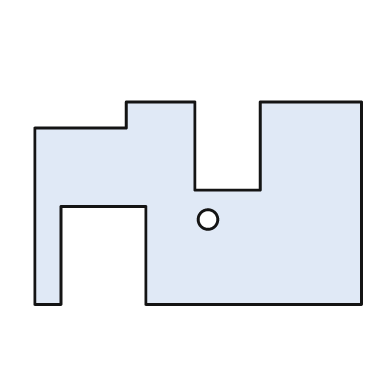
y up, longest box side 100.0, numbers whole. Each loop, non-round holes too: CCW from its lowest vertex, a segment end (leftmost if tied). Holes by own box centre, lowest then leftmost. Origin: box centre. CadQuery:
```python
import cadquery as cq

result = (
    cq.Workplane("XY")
    .moveTo(-50.0, -31.0)
    .lineTo(-42.0, -31.0)
    .lineTo(-42.0, -1.0)
    .lineTo(-16.0, -1.0)
    .lineTo(-16.0, -31.0)
    .lineTo(50.0, -31.0)
    .lineTo(50.0, 31.0)
    .lineTo(19.0, 31.0)
    .lineTo(19.0, 4.0)
    .lineTo(-1.0, 4.0)
    .lineTo(-1.0, 31.0)
    .lineTo(-22.0, 31.0)
    .lineTo(-22.0, 23.0)
    .lineTo(-50.0, 23.0)
    .close()
    .moveTo(3.0, -5.0)
    .circle(3.0)
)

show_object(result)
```